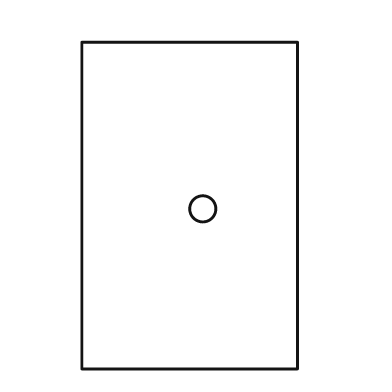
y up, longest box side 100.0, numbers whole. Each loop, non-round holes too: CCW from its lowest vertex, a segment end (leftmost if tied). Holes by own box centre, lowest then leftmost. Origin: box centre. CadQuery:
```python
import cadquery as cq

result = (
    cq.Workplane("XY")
    .moveTo(-33.0, -50.0)
    .lineTo(33.0, -50.0)
    .lineTo(33.0, 50.0)
    .lineTo(-33.0, 50.0)
    .close()
    .moveTo(4.0, -1.0)
    .circle(4.0)
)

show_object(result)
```